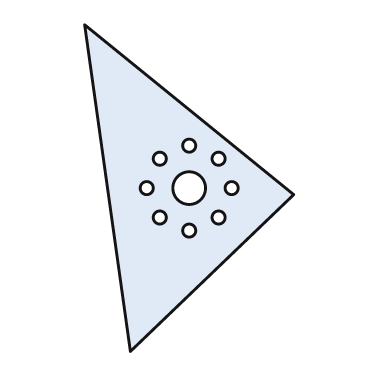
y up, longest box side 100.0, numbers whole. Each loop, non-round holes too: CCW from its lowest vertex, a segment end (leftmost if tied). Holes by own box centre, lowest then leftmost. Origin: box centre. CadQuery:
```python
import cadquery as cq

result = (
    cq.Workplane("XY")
    .moveTo(-18.0, -50.0)
    .lineTo(32.0, -2.0)
    .lineTo(-32.0, 50.0)
    .close()
    .moveTo(0.0, -13.0)
    .circle(2.0)
    .moveTo(-9.0, -9.0)
    .circle(2.0)
    .moveTo(9.0, -9.0)
    .circle(2.0)
    .moveTo(-13.0, 0.0)
    .circle(2.0)
    .moveTo(0.0, 0.0)
    .circle(5.0)
    .moveTo(13.0, 0.0)
    .circle(2.0)
    .moveTo(-9.0, 9.0)
    .circle(2.0)
    .moveTo(9.0, 9.0)
    .circle(2.0)
    .moveTo(0.0, 13.0)
    .circle(2.0)
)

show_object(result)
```